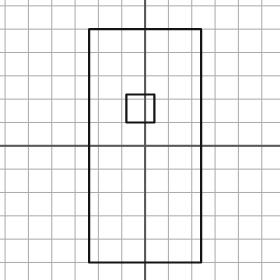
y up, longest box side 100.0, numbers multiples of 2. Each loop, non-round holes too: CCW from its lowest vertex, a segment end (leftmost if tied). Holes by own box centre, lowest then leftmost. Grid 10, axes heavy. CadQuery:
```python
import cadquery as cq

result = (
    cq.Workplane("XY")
    .moveTo(-24.0, -50.0)
    .lineTo(24.0, -50.0)
    .lineTo(24.0, 50.0)
    .lineTo(-24.0, 50.0)
    .close()
    .moveTo(-8.0, 10.0)
    .lineTo(4.0, 10.0)
    .lineTo(4.0, 22.0)
    .lineTo(-8.0, 22.0)
    .close()
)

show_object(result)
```